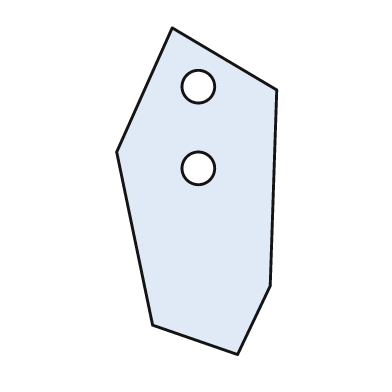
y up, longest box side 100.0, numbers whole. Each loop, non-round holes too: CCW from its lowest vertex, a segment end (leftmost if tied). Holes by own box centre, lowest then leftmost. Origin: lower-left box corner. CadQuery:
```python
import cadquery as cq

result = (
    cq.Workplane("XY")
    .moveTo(37.0, 0.0)
    .lineTo(47.0, 21.0)
    .lineTo(49.0, 81.0)
    .lineTo(17.0, 100.0)
    .lineTo(0.0, 62.0)
    .lineTo(11.0, 9.0)
    .close()
    .moveTo(25.0, 57.0)
    .circle(5.0)
    .moveTo(25.0, 82.0)
    .circle(5.0)
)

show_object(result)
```